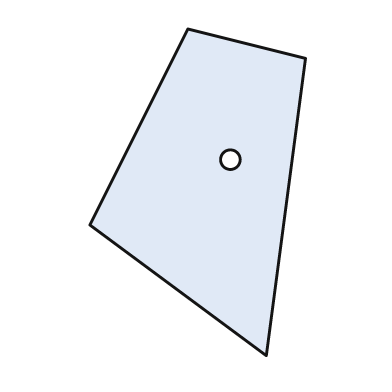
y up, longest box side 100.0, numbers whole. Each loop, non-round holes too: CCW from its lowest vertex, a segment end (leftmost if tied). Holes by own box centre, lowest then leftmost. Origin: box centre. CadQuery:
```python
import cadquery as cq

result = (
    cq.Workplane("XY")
    .moveTo(21.0, -50.0)
    .lineTo(33.0, 41.0)
    .lineTo(-3.0, 50.0)
    .lineTo(-33.0, -10.0)
    .close()
    .moveTo(10.0, 10.0)
    .circle(3.0)
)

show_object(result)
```